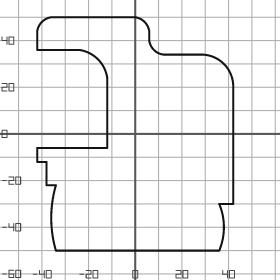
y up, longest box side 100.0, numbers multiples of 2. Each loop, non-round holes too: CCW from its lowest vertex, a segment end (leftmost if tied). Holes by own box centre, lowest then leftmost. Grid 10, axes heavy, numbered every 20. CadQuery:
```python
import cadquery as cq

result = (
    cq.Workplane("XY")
    .moveTo(-34.0, -50.0)
    .lineTo(36.0, -50.0)
    .threePointArc((38.0, -40.0), (36.0, -30.0))
    .lineTo(42.0, -30.0)
    .lineTo(42.0, 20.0)
    .threePointArc((38.0, 30.0), (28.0, 34.0))
    .lineTo(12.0, 34.0)
    .threePointArc((8.0, 36.0), (6.0, 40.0))
    .lineTo(6.0, 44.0)
    .threePointArc((4.0, 48.0), (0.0, 50.0))
    .lineTo(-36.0, 50.0)
    .threePointArc((-40.0, 48.0), (-42.0, 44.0))
    .lineTo(-42.0, 36.0)
    .lineTo(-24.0, 36.0)
    .threePointArc((-16.0, 32.0), (-12.0, 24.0))
    .lineTo(-12.0, -6.0)
    .lineTo(-42.0, -6.0)
    .lineTo(-42.0, -12.0)
    .lineTo(-38.0, -12.0)
    .lineTo(-38.0, -22.0)
    .lineTo(-34.0, -22.0)
    .threePointArc((-36.0, -36.0), (-34.0, -50.0))
    .close()
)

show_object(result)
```